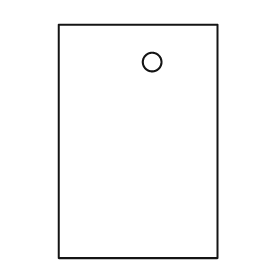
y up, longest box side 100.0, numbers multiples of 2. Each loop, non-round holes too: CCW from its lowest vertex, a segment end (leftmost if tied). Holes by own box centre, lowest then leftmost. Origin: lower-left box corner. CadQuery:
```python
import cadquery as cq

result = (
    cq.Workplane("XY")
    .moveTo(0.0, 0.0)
    .lineTo(68.0, 0.0)
    .lineTo(68.0, 100.0)
    .lineTo(0.0, 100.0)
    .close()
    .moveTo(40.0, 84.0)
    .circle(4.0)
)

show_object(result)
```